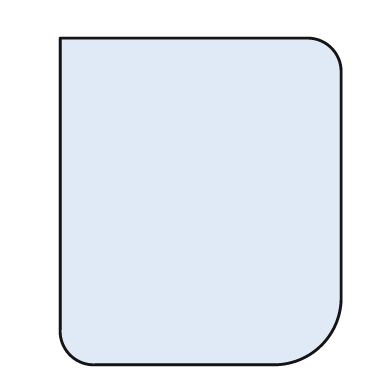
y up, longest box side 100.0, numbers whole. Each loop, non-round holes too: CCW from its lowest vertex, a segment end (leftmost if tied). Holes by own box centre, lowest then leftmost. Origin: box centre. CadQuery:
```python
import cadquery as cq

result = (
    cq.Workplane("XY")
    .moveTo(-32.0, -50.0)
    .lineTo(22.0, -50.0)
    .threePointArc((37.0, -44.0), (43.0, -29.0))
    .lineTo(43.0, 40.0)
    .threePointArc((40.0, 47.0), (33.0, 50.0))
    .lineTo(-43.0, 50.0)
    .lineTo(-43.0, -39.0)
    .threePointArc((-40.0, -47.0), (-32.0, -50.0))
    .close()
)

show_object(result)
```